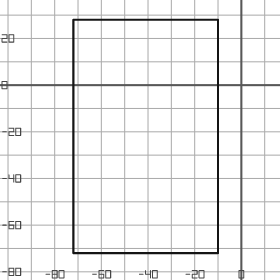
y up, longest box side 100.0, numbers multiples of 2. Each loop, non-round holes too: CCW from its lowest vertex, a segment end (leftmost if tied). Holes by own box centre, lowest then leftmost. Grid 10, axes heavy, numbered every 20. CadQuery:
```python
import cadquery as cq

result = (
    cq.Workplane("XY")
    .moveTo(-72.0, -72.0)
    .lineTo(-10.0, -72.0)
    .lineTo(-10.0, 28.0)
    .lineTo(-72.0, 28.0)
    .close()
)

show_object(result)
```